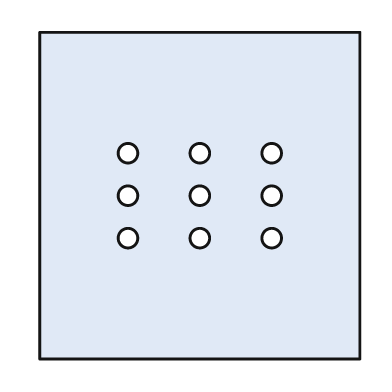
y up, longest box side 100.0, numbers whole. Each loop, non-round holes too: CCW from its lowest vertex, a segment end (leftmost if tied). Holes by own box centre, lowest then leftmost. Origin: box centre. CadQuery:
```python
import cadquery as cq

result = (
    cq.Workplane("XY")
    .moveTo(-49.0, -50.0)
    .lineTo(49.0, -50.0)
    .lineTo(49.0, 50.0)
    .lineTo(-49.0, 50.0)
    .close()
    .moveTo(-22.0, -13.0)
    .circle(3.0)
    .moveTo(0.0, -13.0)
    .circle(3.0)
    .moveTo(22.0, -13.0)
    .circle(3.0)
    .moveTo(-22.0, 0.0)
    .circle(3.0)
    .moveTo(0.0, 0.0)
    .circle(3.0)
    .moveTo(22.0, 0.0)
    .circle(3.0)
    .moveTo(-22.0, 13.0)
    .circle(3.0)
    .moveTo(0.0, 13.0)
    .circle(3.0)
    .moveTo(22.0, 13.0)
    .circle(3.0)
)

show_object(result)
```